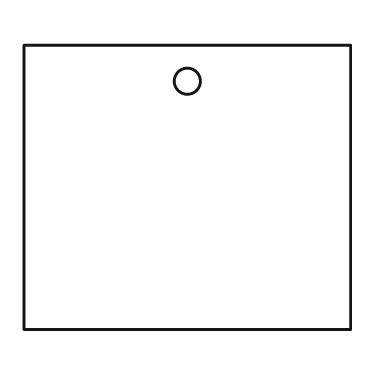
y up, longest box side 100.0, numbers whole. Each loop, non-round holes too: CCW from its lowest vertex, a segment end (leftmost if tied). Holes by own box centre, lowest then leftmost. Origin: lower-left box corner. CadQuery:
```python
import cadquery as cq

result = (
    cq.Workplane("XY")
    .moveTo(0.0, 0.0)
    .lineTo(100.0, 0.0)
    .lineTo(100.0, 87.0)
    .lineTo(0.0, 87.0)
    .close()
    .moveTo(50.0, 76.0)
    .circle(4.0)
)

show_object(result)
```